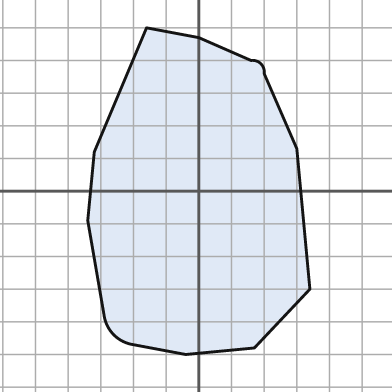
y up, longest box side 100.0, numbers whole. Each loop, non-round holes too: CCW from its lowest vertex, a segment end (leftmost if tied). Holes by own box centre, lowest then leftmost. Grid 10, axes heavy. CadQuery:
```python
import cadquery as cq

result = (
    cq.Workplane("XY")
    .moveTo(-4.0, -50.0)
    .lineTo(17.0, -48.0)
    .lineTo(34.0, -30.0)
    .lineTo(30.0, 13.0)
    .lineTo(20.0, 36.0)
    .threePointArc((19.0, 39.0), (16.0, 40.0))
    .lineTo(0.0, 47.0)
    .lineTo(-16.0, 50.0)
    .lineTo(-32.0, 12.0)
    .lineTo(-34.0, -9.0)
    .lineTo(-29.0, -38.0)
    .threePointArc((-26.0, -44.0), (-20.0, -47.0))
    .close()
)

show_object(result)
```